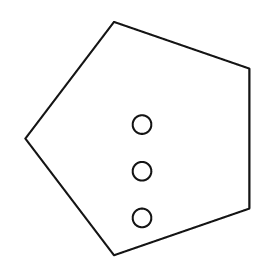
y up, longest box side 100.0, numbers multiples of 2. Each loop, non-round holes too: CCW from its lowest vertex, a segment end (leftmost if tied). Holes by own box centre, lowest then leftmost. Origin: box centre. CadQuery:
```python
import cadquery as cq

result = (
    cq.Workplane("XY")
    .moveTo(-10.0, -50.0)
    .lineTo(48.0, -30.0)
    .lineTo(48.0, 30.0)
    .lineTo(-10.0, 50.0)
    .lineTo(-48.0, 0.0)
    .close()
    .moveTo(2.0, -34.0)
    .circle(4.0)
    .moveTo(2.0, -14.0)
    .circle(4.0)
    .moveTo(2.0, 6.0)
    .circle(4.0)
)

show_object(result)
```